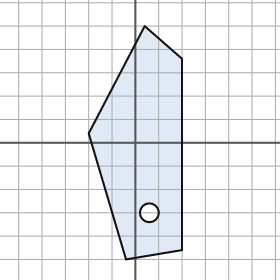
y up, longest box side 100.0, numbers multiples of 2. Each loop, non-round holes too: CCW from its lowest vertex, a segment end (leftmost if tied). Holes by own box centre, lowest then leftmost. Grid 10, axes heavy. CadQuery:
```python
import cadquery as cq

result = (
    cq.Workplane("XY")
    .moveTo(-4.0, -50.0)
    .lineTo(20.0, -46.0)
    .lineTo(20.0, 36.0)
    .lineTo(4.0, 50.0)
    .lineTo(-20.0, 4.0)
    .close()
    .moveTo(6.0, -30.0)
    .circle(4.0)
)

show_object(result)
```